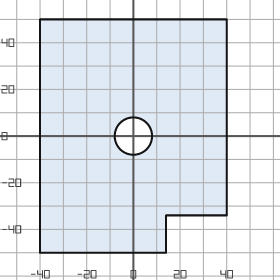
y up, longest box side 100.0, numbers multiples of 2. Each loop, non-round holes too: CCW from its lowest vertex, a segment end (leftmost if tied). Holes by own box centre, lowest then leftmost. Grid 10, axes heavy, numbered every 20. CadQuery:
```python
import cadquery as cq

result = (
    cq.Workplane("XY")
    .moveTo(-40.0, -50.0)
    .lineTo(14.0, -50.0)
    .lineTo(14.0, -34.0)
    .lineTo(40.0, -34.0)
    .lineTo(40.0, 50.0)
    .lineTo(-40.0, 50.0)
    .close()
    .moveTo(0.0, 0.0)
    .circle(8.0)
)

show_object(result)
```